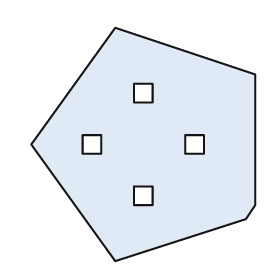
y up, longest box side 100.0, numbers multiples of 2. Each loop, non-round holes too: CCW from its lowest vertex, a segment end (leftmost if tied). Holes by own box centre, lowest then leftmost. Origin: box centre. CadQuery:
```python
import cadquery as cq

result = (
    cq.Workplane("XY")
    .moveTo(-12.0, -50.0)
    .lineTo(44.0, -32.0)
    .lineTo(48.0, -26.0)
    .lineTo(48.0, 30.0)
    .lineTo(-12.0, 50.0)
    .lineTo(-48.0, 0.0)
    .close()
    .moveTo(-4.0, -26.0)
    .lineTo(4.0, -26.0)
    .lineTo(4.0, -18.0)
    .lineTo(-4.0, -18.0)
    .close()
    .moveTo(-26.0, -4.0)
    .lineTo(-18.0, -4.0)
    .lineTo(-18.0, 4.0)
    .lineTo(-26.0, 4.0)
    .close()
    .moveTo(18.0, -4.0)
    .lineTo(26.0, -4.0)
    .lineTo(26.0, 4.0)
    .lineTo(18.0, 4.0)
    .close()
    .moveTo(-4.0, 18.0)
    .lineTo(4.0, 18.0)
    .lineTo(4.0, 26.0)
    .lineTo(-4.0, 26.0)
    .close()
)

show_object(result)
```